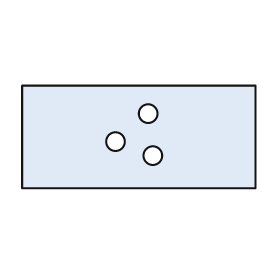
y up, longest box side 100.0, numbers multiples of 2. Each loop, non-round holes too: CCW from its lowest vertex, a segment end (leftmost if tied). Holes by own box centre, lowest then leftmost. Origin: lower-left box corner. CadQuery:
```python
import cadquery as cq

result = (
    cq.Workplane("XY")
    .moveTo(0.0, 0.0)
    .lineTo(100.0, 0.0)
    .lineTo(100.0, 44.0)
    .lineTo(0.0, 44.0)
    .close()
    .moveTo(56.0, 14.0)
    .circle(4.0)
    .moveTo(40.0, 20.0)
    .circle(4.0)
    .moveTo(54.0, 32.0)
    .circle(4.0)
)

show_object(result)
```